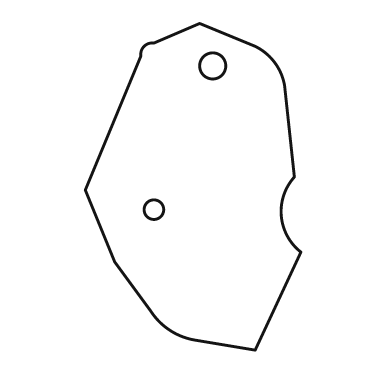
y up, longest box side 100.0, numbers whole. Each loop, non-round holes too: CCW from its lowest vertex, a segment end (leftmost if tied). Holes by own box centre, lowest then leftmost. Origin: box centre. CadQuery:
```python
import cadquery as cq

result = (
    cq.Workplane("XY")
    .moveTo(19.0, -50.0)
    .lineTo(33.0, -20.0)
    .threePointArc((27.0, -9.0), (31.0, 3.0))
    .lineTo(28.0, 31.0)
    .threePointArc((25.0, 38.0), (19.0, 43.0))
    .lineTo(2.0, 50.0)
    .lineTo(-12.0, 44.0)
    .threePointArc((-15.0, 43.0), (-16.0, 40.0))
    .lineTo(-33.0, -1.0)
    .lineTo(-24.0, -23.0)
    .lineTo(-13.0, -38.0)
    .threePointArc((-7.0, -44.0), (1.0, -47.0))
    .close()
    .moveTo(-12.0, -7.0)
    .circle(3.0)
    .moveTo(6.0, 37.0)
    .circle(4.0)
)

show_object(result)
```